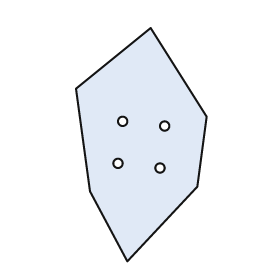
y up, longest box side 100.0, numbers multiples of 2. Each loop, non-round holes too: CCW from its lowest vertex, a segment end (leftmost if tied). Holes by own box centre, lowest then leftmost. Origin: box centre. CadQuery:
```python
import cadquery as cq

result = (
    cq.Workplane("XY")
    .moveTo(-6.0, -50.0)
    .lineTo(24.0, -18.0)
    .lineTo(28.0, 12.0)
    .lineTo(4.0, 50.0)
    .lineTo(-28.0, 24.0)
    .lineTo(-22.0, -20.0)
    .close()
    .moveTo(8.0, -10.0)
    .circle(2.0)
    .moveTo(-10.0, -8.0)
    .circle(2.0)
    .moveTo(10.0, 8.0)
    .circle(2.0)
    .moveTo(-8.0, 10.0)
    .circle(2.0)
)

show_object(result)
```